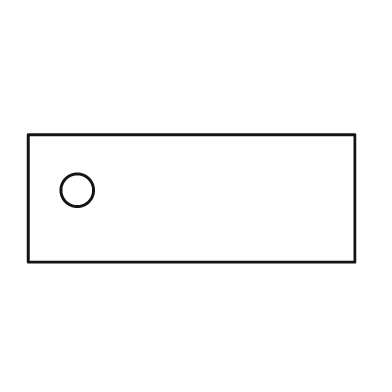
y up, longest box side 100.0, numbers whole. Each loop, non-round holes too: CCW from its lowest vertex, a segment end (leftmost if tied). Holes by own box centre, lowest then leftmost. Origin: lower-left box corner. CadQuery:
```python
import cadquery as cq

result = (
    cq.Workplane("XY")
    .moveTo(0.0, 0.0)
    .lineTo(100.0, 0.0)
    .lineTo(100.0, 39.0)
    .lineTo(0.0, 39.0)
    .close()
    .moveTo(15.0, 22.0)
    .circle(5.0)
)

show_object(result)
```